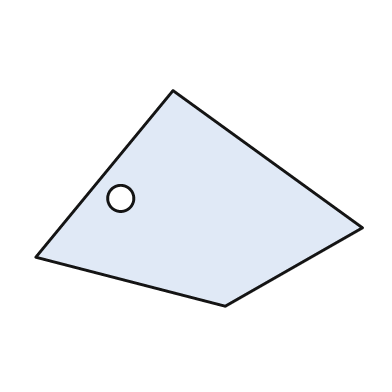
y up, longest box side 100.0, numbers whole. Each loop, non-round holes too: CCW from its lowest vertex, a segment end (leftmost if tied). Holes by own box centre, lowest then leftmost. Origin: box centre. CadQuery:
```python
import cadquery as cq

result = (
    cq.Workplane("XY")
    .moveTo(8.0, -33.0)
    .lineTo(50.0, -9.0)
    .lineTo(-8.0, 33.0)
    .lineTo(-50.0, -18.0)
    .close()
    .moveTo(-24.0, 0.0)
    .circle(4.0)
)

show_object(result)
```